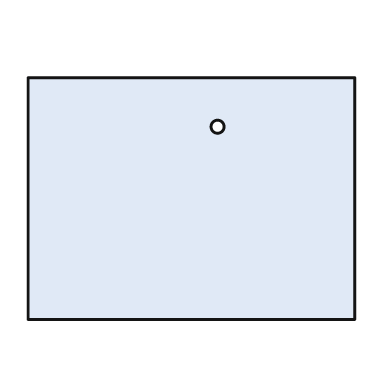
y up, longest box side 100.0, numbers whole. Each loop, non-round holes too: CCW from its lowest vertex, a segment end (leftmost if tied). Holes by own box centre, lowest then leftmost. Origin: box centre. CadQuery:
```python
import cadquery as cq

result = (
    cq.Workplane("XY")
    .moveTo(-50.0, -37.0)
    .lineTo(50.0, -37.0)
    .lineTo(50.0, 37.0)
    .lineTo(-50.0, 37.0)
    .close()
    .moveTo(8.0, 22.0)
    .circle(2.0)
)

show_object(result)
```